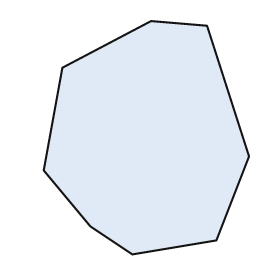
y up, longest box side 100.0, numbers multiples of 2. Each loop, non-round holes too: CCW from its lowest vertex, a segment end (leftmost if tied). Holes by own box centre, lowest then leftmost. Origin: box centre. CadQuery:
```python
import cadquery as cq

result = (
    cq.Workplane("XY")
    .moveTo(-6.0, -50.0)
    .lineTo(30.0, -44.0)
    .lineTo(44.0, -8.0)
    .lineTo(26.0, 48.0)
    .lineTo(2.0, 50.0)
    .lineTo(-36.0, 30.0)
    .lineTo(-44.0, -14.0)
    .lineTo(-24.0, -38.0)
    .close()
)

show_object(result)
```